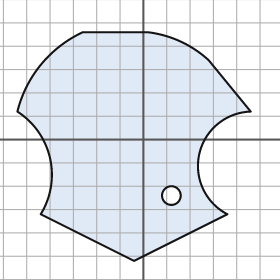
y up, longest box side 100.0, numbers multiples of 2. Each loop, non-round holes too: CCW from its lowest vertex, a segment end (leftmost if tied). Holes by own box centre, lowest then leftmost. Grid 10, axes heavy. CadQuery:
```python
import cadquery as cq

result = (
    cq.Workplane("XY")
    .moveTo(-4.0, -52.0)
    .lineTo(36.0, -32.0)
    .threePointArc((24.0, -6.0), (46.0, 12.0))
    .lineTo(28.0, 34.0)
    .threePointArc((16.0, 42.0), (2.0, 46.0))
    .lineTo(-26.0, 46.0)
    .threePointArc((-44.0, 32.0), (-54.0, 12.0))
    .threePointArc((-40.0, -8.0), (-44.0, -32.0))
    .close()
    .moveTo(12.0, -24.0)
    .circle(4.0)
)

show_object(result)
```